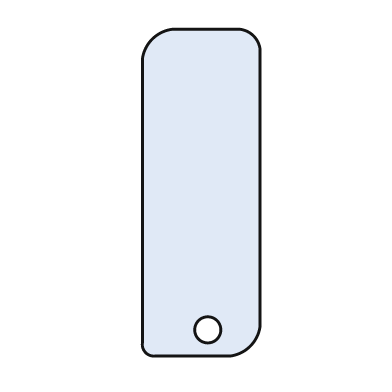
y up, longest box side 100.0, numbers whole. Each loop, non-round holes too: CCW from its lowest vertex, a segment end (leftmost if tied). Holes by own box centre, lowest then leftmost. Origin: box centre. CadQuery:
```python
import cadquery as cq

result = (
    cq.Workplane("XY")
    .moveTo(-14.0, -50.0)
    .lineTo(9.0, -50.0)
    .threePointArc((15.0, -47.0), (18.0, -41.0))
    .lineTo(18.0, 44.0)
    .threePointArc((16.0, 48.0), (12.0, 50.0))
    .lineTo(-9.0, 50.0)
    .threePointArc((-15.0, 47.0), (-18.0, 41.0))
    .lineTo(-18.0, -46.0)
    .threePointArc((-17.0, -49.0), (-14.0, -50.0))
    .close()
    .moveTo(2.0, -42.0)
    .circle(4.0)
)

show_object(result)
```